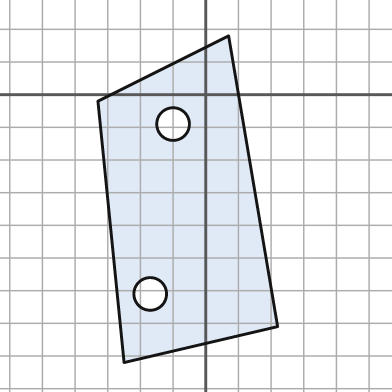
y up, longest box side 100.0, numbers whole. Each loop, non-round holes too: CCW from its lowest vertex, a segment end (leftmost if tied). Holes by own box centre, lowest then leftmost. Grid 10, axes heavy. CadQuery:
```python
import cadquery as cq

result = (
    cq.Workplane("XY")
    .moveTo(-25.0, -82.0)
    .lineTo(22.0, -71.0)
    .lineTo(7.0, 18.0)
    .lineTo(-33.0, -2.0)
    .close()
    .moveTo(-17.0, -61.0)
    .circle(5.0)
    .moveTo(-10.0, -9.0)
    .circle(5.0)
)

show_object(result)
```